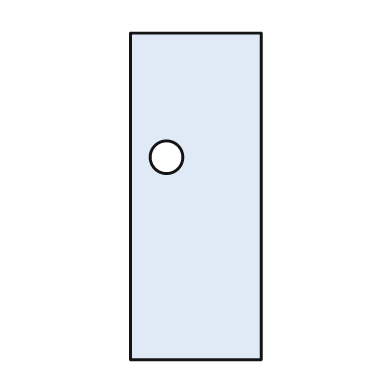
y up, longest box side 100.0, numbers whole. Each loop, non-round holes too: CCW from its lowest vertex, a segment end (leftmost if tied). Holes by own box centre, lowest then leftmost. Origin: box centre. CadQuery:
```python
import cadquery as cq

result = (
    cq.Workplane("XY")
    .moveTo(-20.0, -50.0)
    .lineTo(20.0, -50.0)
    .lineTo(20.0, 50.0)
    .lineTo(-20.0, 50.0)
    .close()
    .moveTo(-9.0, 12.0)
    .circle(5.0)
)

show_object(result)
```